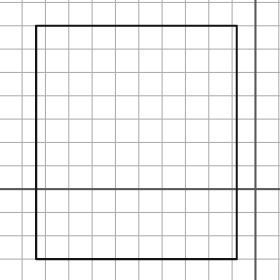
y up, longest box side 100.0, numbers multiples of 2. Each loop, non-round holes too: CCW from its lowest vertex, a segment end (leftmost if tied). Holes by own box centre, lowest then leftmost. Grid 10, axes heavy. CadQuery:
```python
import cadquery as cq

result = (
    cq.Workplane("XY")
    .moveTo(-94.0, -30.0)
    .lineTo(-8.0, -30.0)
    .lineTo(-8.0, 70.0)
    .lineTo(-94.0, 70.0)
    .close()
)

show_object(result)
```